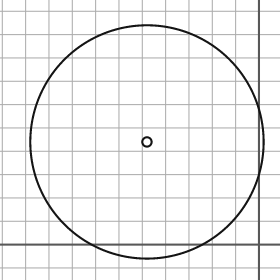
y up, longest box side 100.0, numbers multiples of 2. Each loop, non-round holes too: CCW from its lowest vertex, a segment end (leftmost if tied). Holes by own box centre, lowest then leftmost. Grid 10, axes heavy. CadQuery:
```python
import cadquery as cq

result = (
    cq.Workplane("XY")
    .moveTo(-48.0, 44.0)
    .circle(50.0)
    .moveTo(-48.0, 44.0)
    .circle(2.0)
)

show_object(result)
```